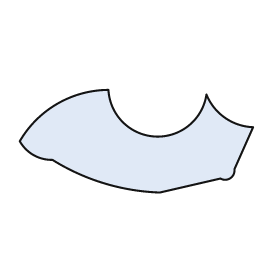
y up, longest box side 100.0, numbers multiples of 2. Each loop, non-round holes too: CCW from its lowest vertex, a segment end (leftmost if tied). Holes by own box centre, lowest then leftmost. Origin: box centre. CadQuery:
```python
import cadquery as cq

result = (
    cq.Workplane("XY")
    .moveTo(10.0, -22.0)
    .lineTo(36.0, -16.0)
    .threePointArc((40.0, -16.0), (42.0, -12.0))
    .lineTo(50.0, 6.0)
    .threePointArc((38.0, 10.0), (30.0, 20.0))
    .threePointArc((8.0, 2.0), (-12.0, 22.0))
    .threePointArc((-34.0, 16.0), (-50.0, 0.0))
    .threePointArc((-44.0, -6.0), (-36.0, -8.0))
    .threePointArc((-14.0, -18.0), (10.0, -22.0))
    .close()
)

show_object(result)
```